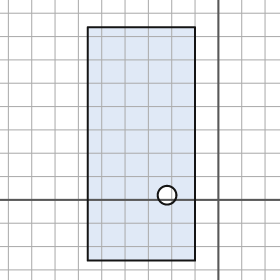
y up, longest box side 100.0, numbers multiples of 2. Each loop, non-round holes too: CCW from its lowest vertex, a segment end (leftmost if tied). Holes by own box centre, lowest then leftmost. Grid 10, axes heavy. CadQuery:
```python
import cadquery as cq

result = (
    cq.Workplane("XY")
    .moveTo(-56.0, -26.0)
    .lineTo(-10.0, -26.0)
    .lineTo(-10.0, 74.0)
    .lineTo(-56.0, 74.0)
    .close()
    .moveTo(-22.0, 2.0)
    .circle(4.0)
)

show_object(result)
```